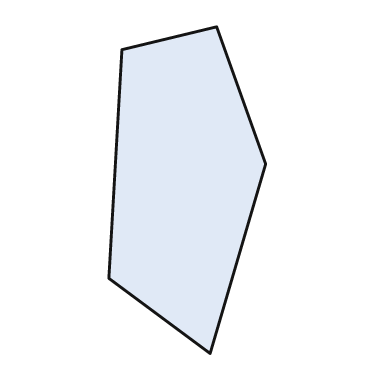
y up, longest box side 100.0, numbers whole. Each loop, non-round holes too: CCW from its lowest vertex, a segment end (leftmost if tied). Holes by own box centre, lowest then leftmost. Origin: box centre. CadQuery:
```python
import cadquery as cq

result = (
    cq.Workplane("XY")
    .moveTo(7.0, -50.0)
    .lineTo(24.0, 8.0)
    .lineTo(9.0, 50.0)
    .lineTo(-20.0, 43.0)
    .lineTo(-24.0, -27.0)
    .close()
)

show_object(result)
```